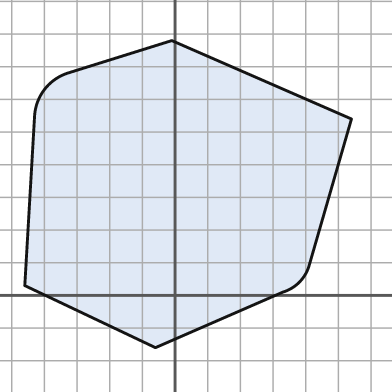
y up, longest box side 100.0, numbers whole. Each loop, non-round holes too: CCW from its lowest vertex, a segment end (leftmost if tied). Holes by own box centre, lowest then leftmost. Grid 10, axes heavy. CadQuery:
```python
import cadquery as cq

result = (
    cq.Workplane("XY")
    .moveTo(-6.0, -16.0)
    .lineTo(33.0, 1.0)
    .threePointArc((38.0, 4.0), (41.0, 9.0))
    .lineTo(54.0, 54.0)
    .lineTo(-1.0, 78.0)
    .lineTo(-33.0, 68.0)
    .threePointArc((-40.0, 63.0), (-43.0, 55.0))
    .lineTo(-46.0, 3.0)
    .close()
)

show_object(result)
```